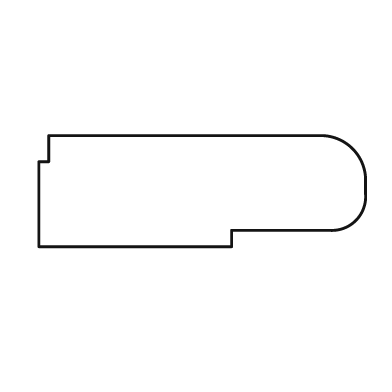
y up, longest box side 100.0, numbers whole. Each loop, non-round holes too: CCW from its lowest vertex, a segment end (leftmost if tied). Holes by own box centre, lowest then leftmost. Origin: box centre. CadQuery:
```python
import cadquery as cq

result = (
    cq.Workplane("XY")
    .moveTo(-50.0, -17.0)
    .lineTo(9.0, -17.0)
    .lineTo(9.0, -12.0)
    .lineTo(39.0, -12.0)
    .threePointArc((47.0, -9.0), (50.0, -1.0))
    .lineTo(50.0, 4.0)
    .threePointArc((46.0, 13.0), (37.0, 17.0))
    .lineTo(-47.0, 17.0)
    .lineTo(-47.0, 9.0)
    .lineTo(-50.0, 9.0)
    .close()
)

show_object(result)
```